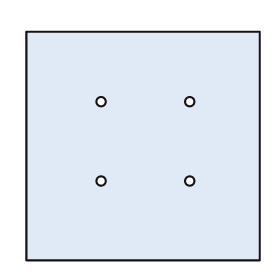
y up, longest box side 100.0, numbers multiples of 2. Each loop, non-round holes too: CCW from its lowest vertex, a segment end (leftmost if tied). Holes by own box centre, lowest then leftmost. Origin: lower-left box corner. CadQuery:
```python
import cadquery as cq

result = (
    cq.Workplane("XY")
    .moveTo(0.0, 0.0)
    .lineTo(100.0, 0.0)
    .lineTo(100.0, 98.0)
    .lineTo(0.0, 98.0)
    .close()
    .moveTo(32.0, 34.0)
    .circle(2.0)
    .moveTo(70.0, 34.0)
    .circle(2.0)
    .moveTo(32.0, 68.0)
    .circle(2.0)
    .moveTo(70.0, 68.0)
    .circle(2.0)
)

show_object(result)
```